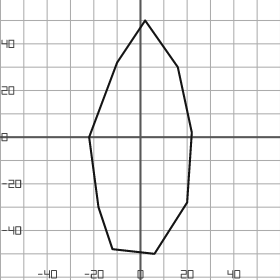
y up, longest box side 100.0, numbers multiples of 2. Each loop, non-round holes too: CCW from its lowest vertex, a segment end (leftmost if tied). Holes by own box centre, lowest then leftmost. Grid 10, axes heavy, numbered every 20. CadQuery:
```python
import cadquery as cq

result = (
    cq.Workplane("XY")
    .moveTo(6.0, -50.0)
    .lineTo(20.0, -28.0)
    .lineTo(22.0, 2.0)
    .lineTo(16.0, 30.0)
    .lineTo(2.0, 50.0)
    .lineTo(-10.0, 32.0)
    .lineTo(-22.0, 0.0)
    .lineTo(-18.0, -30.0)
    .lineTo(-12.0, -48.0)
    .close()
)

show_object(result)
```